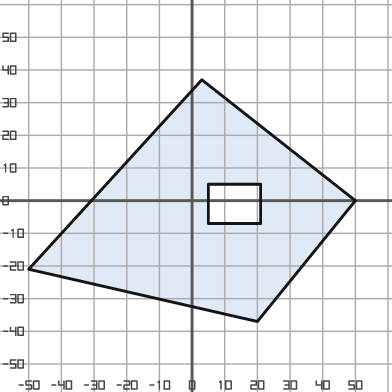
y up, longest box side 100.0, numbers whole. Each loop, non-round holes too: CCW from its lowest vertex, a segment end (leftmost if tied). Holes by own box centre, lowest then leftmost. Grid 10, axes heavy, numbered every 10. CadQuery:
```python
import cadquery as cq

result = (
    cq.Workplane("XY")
    .moveTo(20.0, -37.0)
    .lineTo(50.0, 0.0)
    .lineTo(3.0, 37.0)
    .lineTo(-50.0, -21.0)
    .close()
    .moveTo(5.0, -7.0)
    .lineTo(21.0, -7.0)
    .lineTo(21.0, 5.0)
    .lineTo(5.0, 5.0)
    .close()
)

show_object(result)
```